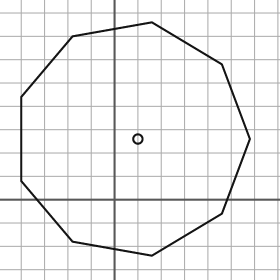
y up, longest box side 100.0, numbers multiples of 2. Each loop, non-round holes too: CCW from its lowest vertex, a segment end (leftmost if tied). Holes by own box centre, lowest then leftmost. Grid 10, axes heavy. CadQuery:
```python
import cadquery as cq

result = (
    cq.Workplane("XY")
    .moveTo(16.0, -24.0)
    .lineTo(46.0, -6.0)
    .lineTo(58.0, 26.0)
    .lineTo(46.0, 58.0)
    .lineTo(16.0, 76.0)
    .lineTo(-18.0, 70.0)
    .lineTo(-40.0, 44.0)
    .lineTo(-40.0, 8.0)
    .lineTo(-18.0, -18.0)
    .close()
    .moveTo(10.0, 26.0)
    .circle(2.0)
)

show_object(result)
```